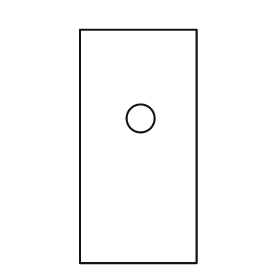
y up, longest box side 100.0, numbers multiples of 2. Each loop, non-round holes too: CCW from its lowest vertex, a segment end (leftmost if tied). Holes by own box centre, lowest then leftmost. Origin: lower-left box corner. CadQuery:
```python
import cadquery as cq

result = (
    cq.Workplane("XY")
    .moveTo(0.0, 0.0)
    .lineTo(50.0, 0.0)
    .lineTo(50.0, 100.0)
    .lineTo(0.0, 100.0)
    .close()
    .moveTo(26.0, 62.0)
    .circle(6.0)
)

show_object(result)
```